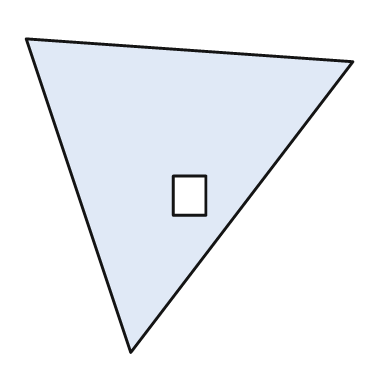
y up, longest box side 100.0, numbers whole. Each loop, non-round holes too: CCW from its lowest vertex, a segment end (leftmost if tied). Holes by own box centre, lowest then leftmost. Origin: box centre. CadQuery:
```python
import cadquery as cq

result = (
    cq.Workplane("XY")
    .moveTo(-18.0, -48.0)
    .lineTo(50.0, 41.0)
    .lineTo(-50.0, 48.0)
    .close()
    .moveTo(-5.0, -6.0)
    .lineTo(5.0, -6.0)
    .lineTo(5.0, 6.0)
    .lineTo(-5.0, 6.0)
    .close()
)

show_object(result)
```